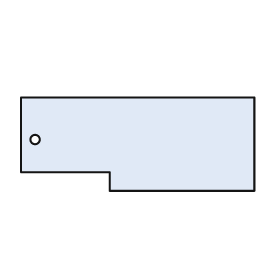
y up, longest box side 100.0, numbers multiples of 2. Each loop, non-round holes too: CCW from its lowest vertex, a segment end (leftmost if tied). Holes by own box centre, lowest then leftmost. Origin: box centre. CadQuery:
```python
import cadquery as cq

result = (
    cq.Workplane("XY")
    .moveTo(-12.0, -20.0)
    .lineTo(50.0, -20.0)
    .lineTo(50.0, 20.0)
    .lineTo(-50.0, 20.0)
    .lineTo(-50.0, -12.0)
    .lineTo(-12.0, -12.0)
    .close()
    .moveTo(-44.0, 2.0)
    .circle(2.0)
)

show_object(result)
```